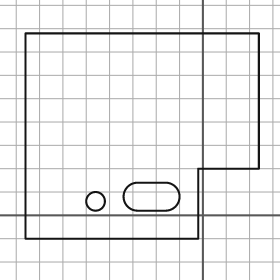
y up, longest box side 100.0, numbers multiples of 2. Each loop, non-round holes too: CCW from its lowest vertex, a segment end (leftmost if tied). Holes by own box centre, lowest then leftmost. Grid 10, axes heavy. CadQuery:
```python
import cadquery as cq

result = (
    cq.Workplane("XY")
    .moveTo(-76.0, -10.0)
    .lineTo(-2.0, -10.0)
    .lineTo(-2.0, 20.0)
    .lineTo(24.0, 20.0)
    .lineTo(24.0, 78.0)
    .lineTo(-76.0, 78.0)
    .close()
    .moveTo(-46.0, 6.0)
    .circle(4.0)
    .moveTo(-28.0, 2.0)
    .lineTo(-16.0, 2.0)
    .threePointArc((-10.0, 8.0), (-16.0, 14.0))
    .lineTo(-28.0, 14.0)
    .threePointArc((-34.0, 8.0), (-28.0, 2.0))
    .close()
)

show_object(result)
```